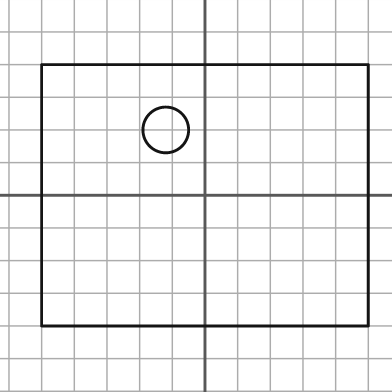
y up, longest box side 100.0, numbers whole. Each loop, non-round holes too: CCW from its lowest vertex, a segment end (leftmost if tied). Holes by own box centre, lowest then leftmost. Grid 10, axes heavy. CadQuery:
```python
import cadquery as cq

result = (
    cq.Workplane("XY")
    .moveTo(-50.0, -40.0)
    .lineTo(50.0, -40.0)
    .lineTo(50.0, 40.0)
    .lineTo(-50.0, 40.0)
    .close()
    .moveTo(-12.0, 20.0)
    .circle(7.0)
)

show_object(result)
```